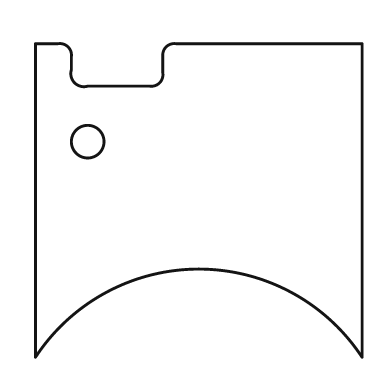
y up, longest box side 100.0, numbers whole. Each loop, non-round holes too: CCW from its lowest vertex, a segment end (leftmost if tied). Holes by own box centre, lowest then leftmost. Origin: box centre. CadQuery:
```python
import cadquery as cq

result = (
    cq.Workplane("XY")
    .moveTo(-50.0, -48.0)
    .threePointArc((0.0, -21.0), (50.0, -48.0))
    .lineTo(50.0, 48.0)
    .lineTo(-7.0, 48.0)
    .threePointArc((-10.0, 47.0), (-11.0, 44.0))
    .lineTo(-11.0, 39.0)
    .threePointArc((-12.0, 36.0), (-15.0, 35.0))
    .lineTo(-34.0, 35.0)
    .threePointArc((-38.0, 36.0), (-39.0, 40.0))
    .lineTo(-39.0, 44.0)
    .threePointArc((-40.0, 47.0), (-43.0, 48.0))
    .lineTo(-50.0, 48.0)
    .close()
    .moveTo(-34.0, 18.0)
    .circle(5.0)
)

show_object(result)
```